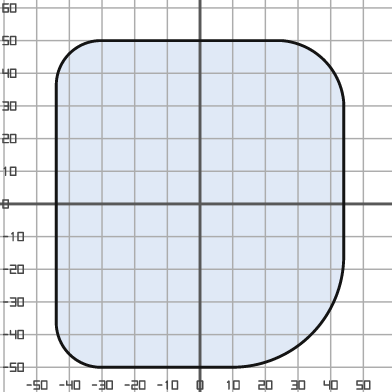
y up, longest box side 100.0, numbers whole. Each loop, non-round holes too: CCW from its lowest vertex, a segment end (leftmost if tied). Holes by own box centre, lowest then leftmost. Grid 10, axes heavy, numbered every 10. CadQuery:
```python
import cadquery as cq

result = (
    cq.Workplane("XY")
    .moveTo(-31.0, -50.0)
    .lineTo(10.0, -50.0)
    .threePointArc((34.0, -40.0), (44.0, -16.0))
    .lineTo(44.0, 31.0)
    .threePointArc((38.0, 44.0), (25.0, 50.0))
    .lineTo(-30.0, 50.0)
    .threePointArc((-40.0, 46.0), (-44.0, 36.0))
    .lineTo(-44.0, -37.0)
    .threePointArc((-40.0, -46.0), (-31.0, -50.0))
    .close()
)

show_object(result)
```